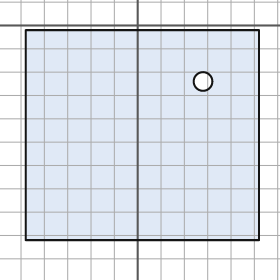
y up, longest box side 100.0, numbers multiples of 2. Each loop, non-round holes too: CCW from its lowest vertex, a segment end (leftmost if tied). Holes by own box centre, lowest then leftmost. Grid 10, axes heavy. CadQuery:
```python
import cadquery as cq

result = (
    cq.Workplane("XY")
    .moveTo(-48.0, -92.0)
    .lineTo(52.0, -92.0)
    .lineTo(52.0, -2.0)
    .lineTo(-48.0, -2.0)
    .close()
    .moveTo(28.0, -24.0)
    .circle(4.0)
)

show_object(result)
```